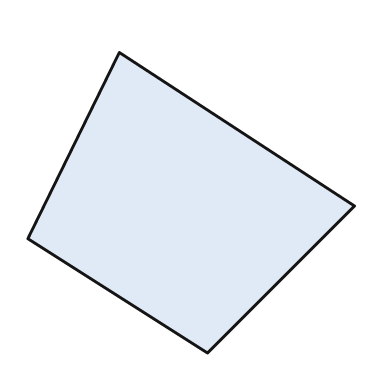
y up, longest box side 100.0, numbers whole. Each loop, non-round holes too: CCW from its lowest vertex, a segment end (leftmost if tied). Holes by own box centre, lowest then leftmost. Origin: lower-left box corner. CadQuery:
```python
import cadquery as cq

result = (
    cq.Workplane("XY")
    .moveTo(55.0, 0.0)
    .lineTo(100.0, 45.0)
    .lineTo(28.0, 92.0)
    .lineTo(0.0, 35.0)
    .close()
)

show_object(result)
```